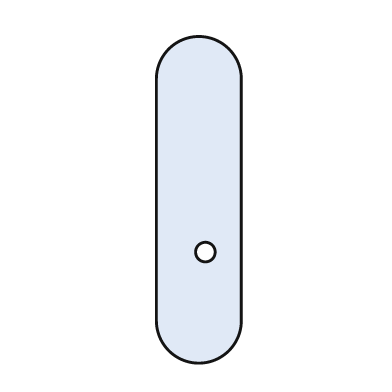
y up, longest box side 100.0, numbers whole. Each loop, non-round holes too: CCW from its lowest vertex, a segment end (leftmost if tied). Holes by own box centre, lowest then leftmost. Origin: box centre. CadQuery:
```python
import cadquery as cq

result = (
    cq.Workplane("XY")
    .moveTo(-13.0, -37.0)
    .threePointArc((0.0, -50.0), (13.0, -37.0))
    .lineTo(13.0, 37.0)
    .threePointArc((0.0, 50.0), (-13.0, 37.0))
    .close()
    .moveTo(2.0, -16.0)
    .circle(3.0)
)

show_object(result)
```